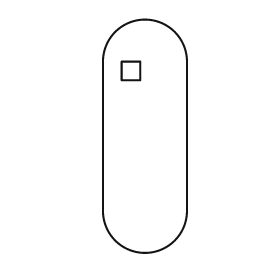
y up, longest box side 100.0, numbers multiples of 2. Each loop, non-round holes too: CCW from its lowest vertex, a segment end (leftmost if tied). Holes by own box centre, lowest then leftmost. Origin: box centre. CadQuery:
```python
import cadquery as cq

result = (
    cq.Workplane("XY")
    .moveTo(-18.0, -32.0)
    .threePointArc((0.0, -50.0), (18.0, -32.0))
    .lineTo(18.0, 32.0)
    .threePointArc((0.0, 50.0), (-18.0, 32.0))
    .close()
    .moveTo(-10.0, 24.0)
    .lineTo(-2.0, 24.0)
    .lineTo(-2.0, 32.0)
    .lineTo(-10.0, 32.0)
    .close()
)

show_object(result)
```